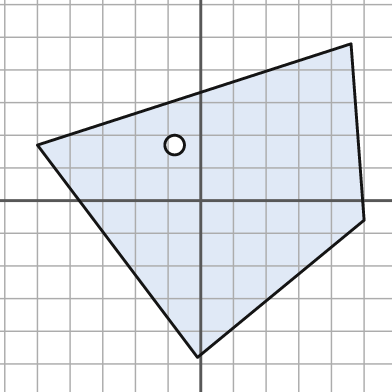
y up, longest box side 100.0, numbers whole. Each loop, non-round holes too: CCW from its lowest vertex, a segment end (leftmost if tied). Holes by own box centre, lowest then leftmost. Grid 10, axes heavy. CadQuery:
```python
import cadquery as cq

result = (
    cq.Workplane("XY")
    .moveTo(-1.0, -48.0)
    .lineTo(50.0, -6.0)
    .lineTo(46.0, 48.0)
    .lineTo(-50.0, 17.0)
    .close()
    .moveTo(-8.0, 17.0)
    .circle(3.0)
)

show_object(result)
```